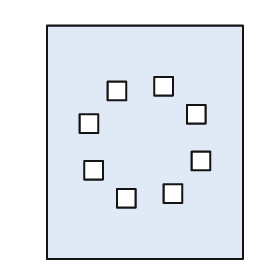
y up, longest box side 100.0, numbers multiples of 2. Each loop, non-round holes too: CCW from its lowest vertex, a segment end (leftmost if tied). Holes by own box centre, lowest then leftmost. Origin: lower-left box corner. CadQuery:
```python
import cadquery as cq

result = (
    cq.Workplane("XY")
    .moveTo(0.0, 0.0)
    .lineTo(84.0, 0.0)
    .lineTo(84.0, 100.0)
    .lineTo(0.0, 100.0)
    .close()
    .moveTo(30.0, 22.0)
    .lineTo(38.0, 22.0)
    .lineTo(38.0, 30.0)
    .lineTo(30.0, 30.0)
    .close()
    .moveTo(50.0, 24.0)
    .lineTo(58.0, 24.0)
    .lineTo(58.0, 32.0)
    .lineTo(50.0, 32.0)
    .close()
    .moveTo(16.0, 34.0)
    .lineTo(24.0, 34.0)
    .lineTo(24.0, 42.0)
    .lineTo(16.0, 42.0)
    .close()
    .moveTo(62.0, 38.0)
    .lineTo(70.0, 38.0)
    .lineTo(70.0, 46.0)
    .lineTo(62.0, 46.0)
    .close()
    .moveTo(14.0, 54.0)
    .lineTo(22.0, 54.0)
    .lineTo(22.0, 62.0)
    .lineTo(14.0, 62.0)
    .close()
    .moveTo(60.0, 58.0)
    .lineTo(68.0, 58.0)
    .lineTo(68.0, 66.0)
    .lineTo(60.0, 66.0)
    .close()
    .moveTo(26.0, 68.0)
    .lineTo(34.0, 68.0)
    .lineTo(34.0, 76.0)
    .lineTo(26.0, 76.0)
    .close()
    .moveTo(46.0, 70.0)
    .lineTo(54.0, 70.0)
    .lineTo(54.0, 78.0)
    .lineTo(46.0, 78.0)
    .close()
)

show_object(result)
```